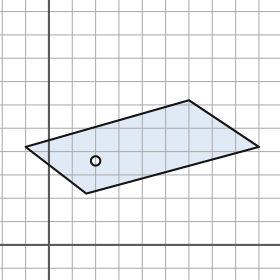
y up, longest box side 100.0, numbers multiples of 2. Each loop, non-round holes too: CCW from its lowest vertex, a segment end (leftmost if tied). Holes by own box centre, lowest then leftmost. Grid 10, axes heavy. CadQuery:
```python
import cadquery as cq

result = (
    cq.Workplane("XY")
    .moveTo(16.0, 22.0)
    .lineTo(90.0, 42.0)
    .lineTo(60.0, 62.0)
    .lineTo(-10.0, 42.0)
    .close()
    .moveTo(20.0, 36.0)
    .circle(2.0)
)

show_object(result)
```